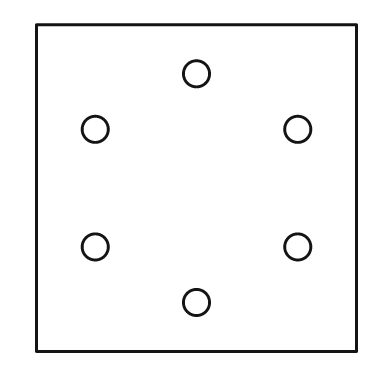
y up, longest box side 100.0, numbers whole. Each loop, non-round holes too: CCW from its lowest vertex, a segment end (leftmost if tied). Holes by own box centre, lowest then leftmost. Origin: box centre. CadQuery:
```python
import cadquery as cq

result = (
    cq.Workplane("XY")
    .moveTo(-49.0, -50.0)
    .lineTo(49.0, -50.0)
    .lineTo(49.0, 50.0)
    .lineTo(-49.0, 50.0)
    .close()
    .moveTo(0.0, -35.0)
    .circle(4.0)
    .moveTo(-31.0, -18.0)
    .circle(4.0)
    .moveTo(31.0, -18.0)
    .circle(4.0)
    .moveTo(-31.0, 18.0)
    .circle(4.0)
    .moveTo(31.0, 18.0)
    .circle(4.0)
    .moveTo(0.0, 35.0)
    .circle(4.0)
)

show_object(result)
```